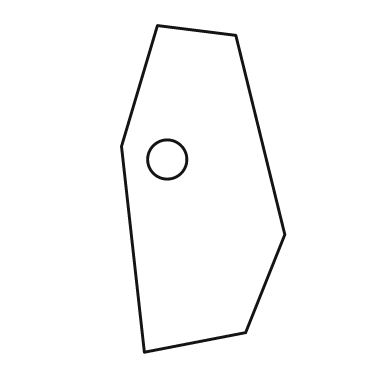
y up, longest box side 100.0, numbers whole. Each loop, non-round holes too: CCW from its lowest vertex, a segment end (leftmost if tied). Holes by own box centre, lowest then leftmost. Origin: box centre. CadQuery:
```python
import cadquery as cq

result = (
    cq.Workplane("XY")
    .moveTo(-18.0, -50.0)
    .lineTo(13.0, -44.0)
    .lineTo(25.0, -14.0)
    .lineTo(10.0, 47.0)
    .lineTo(-14.0, 50.0)
    .lineTo(-25.0, 13.0)
    .close()
    .moveTo(-11.0, 9.0)
    .circle(6.0)
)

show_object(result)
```